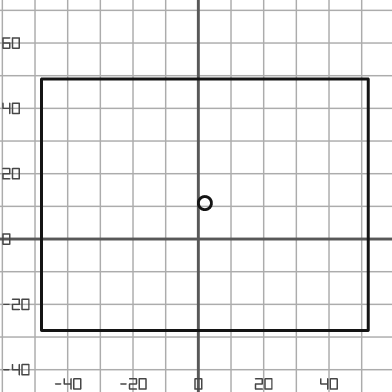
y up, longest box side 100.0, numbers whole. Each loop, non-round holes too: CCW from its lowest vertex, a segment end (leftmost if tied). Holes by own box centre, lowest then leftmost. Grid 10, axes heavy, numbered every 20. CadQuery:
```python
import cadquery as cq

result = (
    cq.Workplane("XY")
    .moveTo(-48.0, -28.0)
    .lineTo(52.0, -28.0)
    .lineTo(52.0, 49.0)
    .lineTo(-48.0, 49.0)
    .close()
    .moveTo(2.0, 11.0)
    .circle(2.0)
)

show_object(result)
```